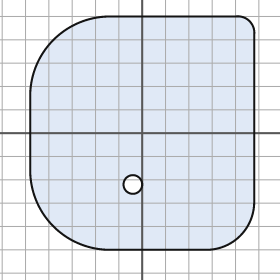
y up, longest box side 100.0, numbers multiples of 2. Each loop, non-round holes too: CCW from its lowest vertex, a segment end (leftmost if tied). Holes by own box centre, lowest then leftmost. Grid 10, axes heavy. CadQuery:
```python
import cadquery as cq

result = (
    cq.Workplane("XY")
    .moveTo(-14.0, -50.0)
    .lineTo(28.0, -50.0)
    .threePointArc((42.0, -44.0), (48.0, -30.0))
    .lineTo(48.0, 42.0)
    .threePointArc((46.0, 48.0), (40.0, 50.0))
    .lineTo(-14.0, 50.0)
    .threePointArc((-38.0, 40.0), (-48.0, 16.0))
    .lineTo(-48.0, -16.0)
    .threePointArc((-38.0, -40.0), (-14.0, -50.0))
    .close()
    .moveTo(-4.0, -22.0)
    .circle(4.0)
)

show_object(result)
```